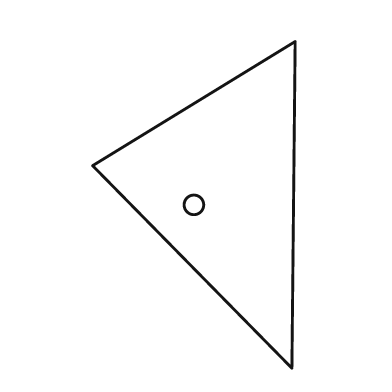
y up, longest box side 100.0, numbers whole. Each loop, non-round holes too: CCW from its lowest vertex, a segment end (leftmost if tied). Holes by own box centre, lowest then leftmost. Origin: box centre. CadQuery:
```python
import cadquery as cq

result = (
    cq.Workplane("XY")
    .moveTo(30.0, -50.0)
    .lineTo(31.0, 50.0)
    .lineTo(-31.0, 12.0)
    .close()
    .moveTo(0.0, 0.0)
    .circle(3.0)
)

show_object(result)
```